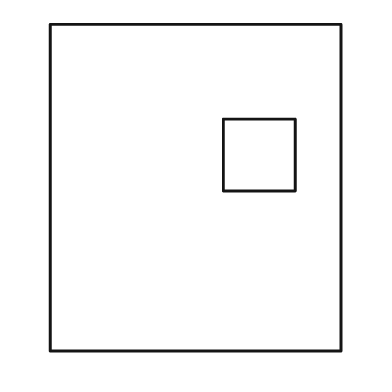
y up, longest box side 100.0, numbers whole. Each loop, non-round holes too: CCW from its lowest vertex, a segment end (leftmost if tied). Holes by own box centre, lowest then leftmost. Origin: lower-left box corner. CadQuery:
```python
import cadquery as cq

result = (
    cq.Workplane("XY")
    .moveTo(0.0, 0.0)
    .lineTo(89.0, 0.0)
    .lineTo(89.0, 100.0)
    .lineTo(0.0, 100.0)
    .close()
    .moveTo(53.0, 49.0)
    .lineTo(75.0, 49.0)
    .lineTo(75.0, 71.0)
    .lineTo(53.0, 71.0)
    .close()
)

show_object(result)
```